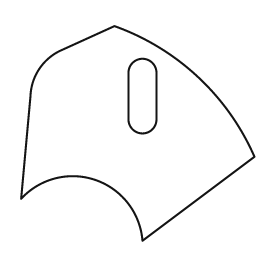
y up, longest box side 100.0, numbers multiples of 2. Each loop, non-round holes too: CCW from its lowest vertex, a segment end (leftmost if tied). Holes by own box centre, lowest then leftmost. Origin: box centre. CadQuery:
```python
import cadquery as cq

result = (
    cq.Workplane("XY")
    .moveTo(2.0, -46.0)
    .lineTo(50.0, -10.0)
    .threePointArc((26.0, 24.0), (-10.0, 46.0))
    .lineTo(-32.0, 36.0)
    .threePointArc((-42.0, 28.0), (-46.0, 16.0))
    .lineTo(-50.0, -28.0)
    .threePointArc((-18.0, -20.0), (2.0, -46.0))
    .close()
    .moveTo(-4.0, 6.0)
    .threePointArc((2.0, 0.0), (8.0, 6.0))
    .lineTo(8.0, 26.0)
    .threePointArc((2.0, 32.0), (-4.0, 26.0))
    .close()
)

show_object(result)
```